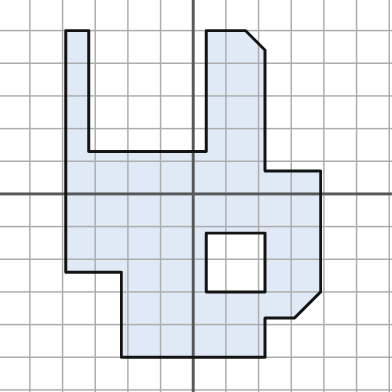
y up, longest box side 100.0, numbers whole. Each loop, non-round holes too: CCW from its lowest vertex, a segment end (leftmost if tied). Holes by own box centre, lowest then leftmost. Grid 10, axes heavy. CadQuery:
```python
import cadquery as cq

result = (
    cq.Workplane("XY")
    .moveTo(-22.0, -50.0)
    .lineTo(22.0, -50.0)
    .lineTo(22.0, -38.0)
    .lineTo(31.0, -38.0)
    .lineTo(39.0, -30.0)
    .lineTo(39.0, 7.0)
    .lineTo(22.0, 7.0)
    .lineTo(22.0, 44.0)
    .lineTo(16.0, 50.0)
    .lineTo(4.0, 50.0)
    .lineTo(4.0, 13.0)
    .lineTo(-32.0, 13.0)
    .lineTo(-32.0, 50.0)
    .lineTo(-39.0, 50.0)
    .lineTo(-39.0, -24.0)
    .lineTo(-22.0, -24.0)
    .close()
    .moveTo(4.0, -30.0)
    .lineTo(22.0, -30.0)
    .lineTo(22.0, -12.0)
    .lineTo(4.0, -12.0)
    .close()
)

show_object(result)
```